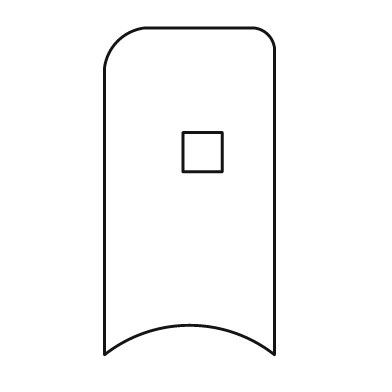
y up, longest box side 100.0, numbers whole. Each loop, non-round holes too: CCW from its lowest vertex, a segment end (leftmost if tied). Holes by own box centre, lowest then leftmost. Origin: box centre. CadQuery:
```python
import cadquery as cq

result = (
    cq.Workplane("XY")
    .moveTo(-26.0, -50.0)
    .threePointArc((0.0, -41.0), (26.0, -50.0))
    .lineTo(26.0, 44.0)
    .threePointArc((24.0, 48.0), (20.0, 50.0))
    .lineTo(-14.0, 50.0)
    .threePointArc((-22.0, 46.0), (-26.0, 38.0))
    .close()
    .moveTo(-2.0, 6.0)
    .lineTo(10.0, 6.0)
    .lineTo(10.0, 18.0)
    .lineTo(-2.0, 18.0)
    .close()
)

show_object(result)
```